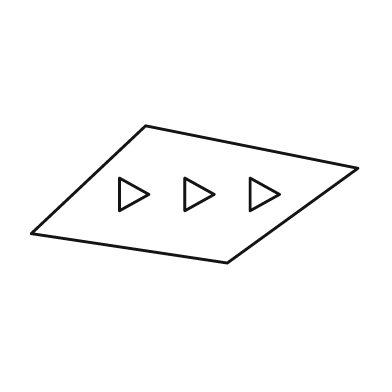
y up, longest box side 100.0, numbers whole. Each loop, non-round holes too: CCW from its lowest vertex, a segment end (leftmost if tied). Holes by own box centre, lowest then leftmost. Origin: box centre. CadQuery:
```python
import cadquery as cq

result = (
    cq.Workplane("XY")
    .moveTo(10.0, -21.0)
    .lineTo(50.0, 8.0)
    .lineTo(-15.0, 21.0)
    .lineTo(-50.0, -12.0)
    .close()
    .moveTo(-23.0, -5.0)
    .lineTo(-14.0, 0.0)
    .lineTo(-23.0, 5.0)
    .close()
    .moveTo(-3.0, -5.0)
    .lineTo(6.0, 0.0)
    .lineTo(-3.0, 5.0)
    .close()
    .moveTo(17.0, -5.0)
    .lineTo(26.0, 0.0)
    .lineTo(17.0, 5.0)
    .close()
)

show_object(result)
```